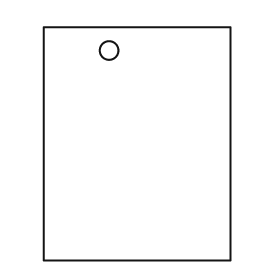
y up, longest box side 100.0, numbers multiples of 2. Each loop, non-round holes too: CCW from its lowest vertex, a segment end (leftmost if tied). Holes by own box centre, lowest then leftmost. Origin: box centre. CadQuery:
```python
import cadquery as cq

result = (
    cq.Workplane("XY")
    .moveTo(-40.0, -50.0)
    .lineTo(40.0, -50.0)
    .lineTo(40.0, 50.0)
    .lineTo(-40.0, 50.0)
    .close()
    .moveTo(-12.0, 40.0)
    .circle(4.0)
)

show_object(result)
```